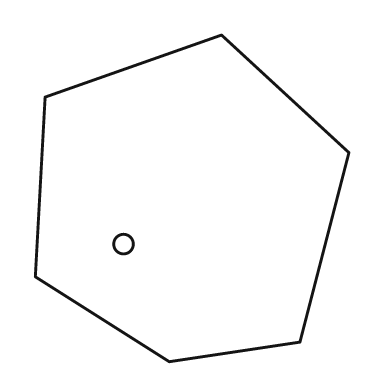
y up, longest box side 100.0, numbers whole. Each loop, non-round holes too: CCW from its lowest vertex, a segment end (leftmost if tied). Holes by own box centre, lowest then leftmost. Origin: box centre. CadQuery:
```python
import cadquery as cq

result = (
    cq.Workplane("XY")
    .moveTo(-7.0, -50.0)
    .lineTo(33.0, -44.0)
    .lineTo(48.0, 14.0)
    .lineTo(9.0, 50.0)
    .lineTo(-45.0, 31.0)
    .lineTo(-48.0, -24.0)
    .close()
    .moveTo(-21.0, -14.0)
    .circle(3.0)
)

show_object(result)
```